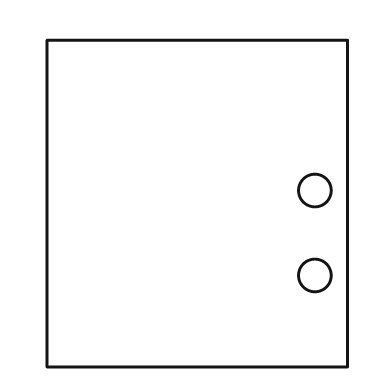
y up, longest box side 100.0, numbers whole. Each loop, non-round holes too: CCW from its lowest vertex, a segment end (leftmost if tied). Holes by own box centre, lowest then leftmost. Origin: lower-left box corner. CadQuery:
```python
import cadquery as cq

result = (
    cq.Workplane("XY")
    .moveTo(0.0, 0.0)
    .lineTo(92.0, 0.0)
    .lineTo(92.0, 100.0)
    .lineTo(0.0, 100.0)
    .close()
    .moveTo(82.0, 28.0)
    .circle(5.0)
    .moveTo(82.0, 54.0)
    .circle(5.0)
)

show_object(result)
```